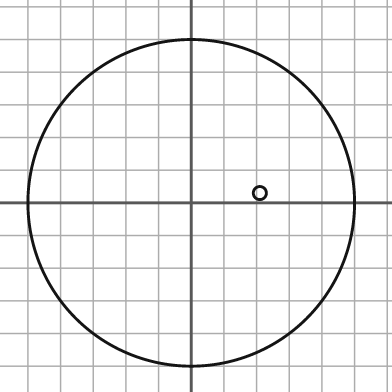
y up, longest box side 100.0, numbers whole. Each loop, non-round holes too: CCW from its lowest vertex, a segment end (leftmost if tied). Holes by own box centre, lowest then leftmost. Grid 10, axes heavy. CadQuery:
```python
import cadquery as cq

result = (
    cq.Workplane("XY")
    .moveTo(0.0, 0.0)
    .circle(50.0)
    .moveTo(21.0, 3.0)
    .circle(2.0)
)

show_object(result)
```